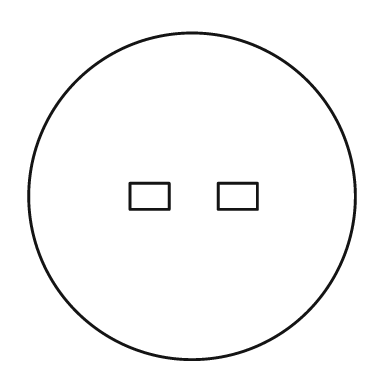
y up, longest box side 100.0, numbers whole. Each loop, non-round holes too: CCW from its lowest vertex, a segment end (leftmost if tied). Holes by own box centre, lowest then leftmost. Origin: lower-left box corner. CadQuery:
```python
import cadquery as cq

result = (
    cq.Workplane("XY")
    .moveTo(50.0, 50.0)
    .circle(50.0)
    .moveTo(31.0, 46.0)
    .lineTo(43.0, 46.0)
    .lineTo(43.0, 54.0)
    .lineTo(31.0, 54.0)
    .close()
    .moveTo(58.0, 46.0)
    .lineTo(70.0, 46.0)
    .lineTo(70.0, 54.0)
    .lineTo(58.0, 54.0)
    .close()
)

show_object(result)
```